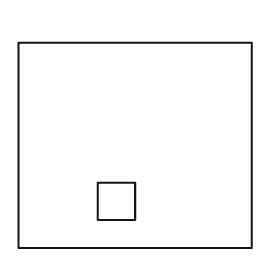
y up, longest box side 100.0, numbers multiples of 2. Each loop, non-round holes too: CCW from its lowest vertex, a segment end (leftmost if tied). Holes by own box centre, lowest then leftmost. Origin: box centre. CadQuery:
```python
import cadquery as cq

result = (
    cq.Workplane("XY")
    .moveTo(-50.0, -44.0)
    .lineTo(50.0, -44.0)
    .lineTo(50.0, 44.0)
    .lineTo(-50.0, 44.0)
    .close()
    .moveTo(-16.0, -32.0)
    .lineTo(0.0, -32.0)
    .lineTo(0.0, -16.0)
    .lineTo(-16.0, -16.0)
    .close()
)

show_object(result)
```